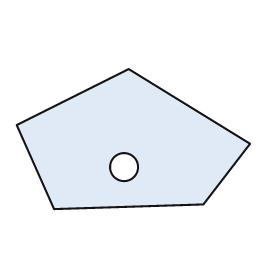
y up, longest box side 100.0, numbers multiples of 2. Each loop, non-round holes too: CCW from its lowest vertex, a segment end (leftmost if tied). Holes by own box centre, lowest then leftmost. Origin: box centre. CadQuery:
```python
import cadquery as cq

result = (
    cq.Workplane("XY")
    .moveTo(-34.0, -30.0)
    .lineTo(30.0, -28.0)
    .lineTo(50.0, -2.0)
    .lineTo(-2.0, 30.0)
    .lineTo(-50.0, 6.0)
    .close()
    .moveTo(-4.0, -12.0)
    .circle(6.0)
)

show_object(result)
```